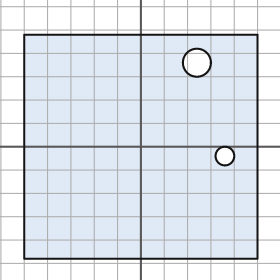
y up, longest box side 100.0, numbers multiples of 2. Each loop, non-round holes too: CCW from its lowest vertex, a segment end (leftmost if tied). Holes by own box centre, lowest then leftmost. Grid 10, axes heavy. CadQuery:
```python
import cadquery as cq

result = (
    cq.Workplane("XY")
    .moveTo(-50.0, -48.0)
    .lineTo(50.0, -48.0)
    .lineTo(50.0, 48.0)
    .lineTo(-50.0, 48.0)
    .close()
    .moveTo(36.0, -4.0)
    .circle(4.0)
    .moveTo(24.0, 36.0)
    .circle(6.0)
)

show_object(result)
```